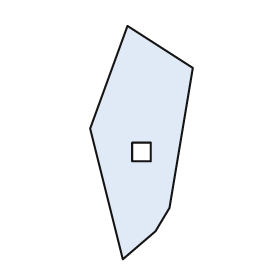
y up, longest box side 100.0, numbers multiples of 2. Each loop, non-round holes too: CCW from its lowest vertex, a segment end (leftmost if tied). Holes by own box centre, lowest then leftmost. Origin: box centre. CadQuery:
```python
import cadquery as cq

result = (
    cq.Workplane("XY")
    .moveTo(-8.0, -50.0)
    .lineTo(6.0, -38.0)
    .lineTo(12.0, -28.0)
    .lineTo(22.0, 32.0)
    .lineTo(-6.0, 50.0)
    .lineTo(-22.0, 6.0)
    .close()
    .moveTo(-4.0, -8.0)
    .lineTo(4.0, -8.0)
    .lineTo(4.0, 0.0)
    .lineTo(-4.0, 0.0)
    .close()
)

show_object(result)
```